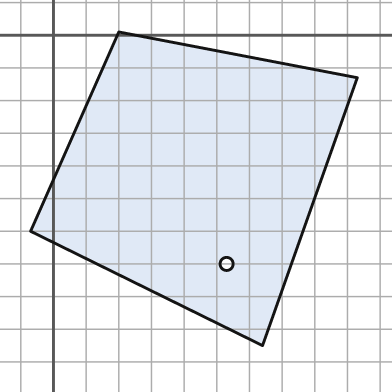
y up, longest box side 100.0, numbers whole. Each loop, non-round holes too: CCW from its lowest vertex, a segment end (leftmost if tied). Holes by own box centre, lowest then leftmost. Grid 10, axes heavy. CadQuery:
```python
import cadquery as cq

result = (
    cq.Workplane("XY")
    .moveTo(64.0, -95.0)
    .lineTo(93.0, -13.0)
    .lineTo(20.0, 1.0)
    .lineTo(-7.0, -60.0)
    .close()
    .moveTo(53.0, -70.0)
    .circle(2.0)
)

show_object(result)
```